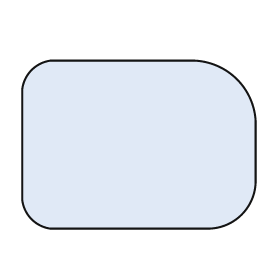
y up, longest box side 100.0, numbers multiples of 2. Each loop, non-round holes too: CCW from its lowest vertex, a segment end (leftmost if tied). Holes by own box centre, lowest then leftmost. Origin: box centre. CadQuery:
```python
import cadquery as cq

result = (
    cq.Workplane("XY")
    .moveTo(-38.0, -36.0)
    .lineTo(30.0, -36.0)
    .threePointArc((44.0, -30.0), (50.0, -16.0))
    .lineTo(50.0, 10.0)
    .threePointArc((42.0, 28.0), (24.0, 36.0))
    .lineTo(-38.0, 36.0)
    .threePointArc((-46.0, 32.0), (-50.0, 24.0))
    .lineTo(-50.0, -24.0)
    .threePointArc((-46.0, -32.0), (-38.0, -36.0))
    .close()
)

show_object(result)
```